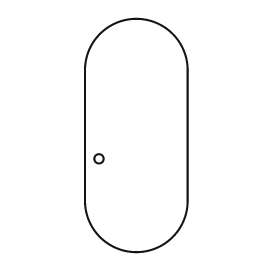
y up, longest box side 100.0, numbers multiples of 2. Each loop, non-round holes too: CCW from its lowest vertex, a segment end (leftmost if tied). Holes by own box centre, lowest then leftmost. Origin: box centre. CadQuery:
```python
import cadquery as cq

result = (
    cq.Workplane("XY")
    .moveTo(-22.0, -28.0)
    .threePointArc((0.0, -50.0), (22.0, -28.0))
    .lineTo(22.0, 28.0)
    .threePointArc((0.0, 50.0), (-22.0, 28.0))
    .close()
    .moveTo(-16.0, -10.0)
    .circle(2.0)
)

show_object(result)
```